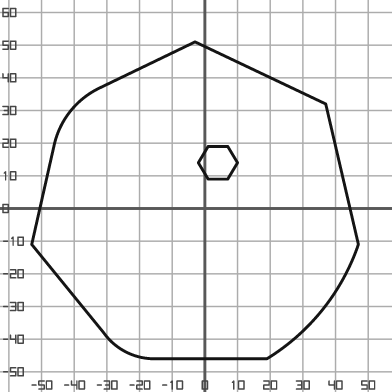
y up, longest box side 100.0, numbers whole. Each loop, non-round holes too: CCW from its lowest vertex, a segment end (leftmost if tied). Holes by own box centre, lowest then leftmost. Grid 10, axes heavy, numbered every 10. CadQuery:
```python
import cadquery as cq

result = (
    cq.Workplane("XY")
    .moveTo(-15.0, -46.0)
    .lineTo(19.0, -46.0)
    .threePointArc((36.0, -31.0), (47.0, -11.0))
    .lineTo(37.0, 32.0)
    .lineTo(-3.0, 51.0)
    .lineTo(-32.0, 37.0)
    .threePointArc((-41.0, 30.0), (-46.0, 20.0))
    .lineTo(-53.0, -11.0)
    .lineTo(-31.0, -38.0)
    .threePointArc((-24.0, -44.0), (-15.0, -46.0))
    .close()
    .moveTo(1.0, 9.0)
    .lineTo(7.0, 9.0)
    .lineTo(10.0, 14.0)
    .lineTo(7.0, 19.0)
    .lineTo(1.0, 19.0)
    .lineTo(-2.0, 14.0)
    .close()
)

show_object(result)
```